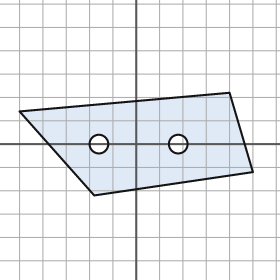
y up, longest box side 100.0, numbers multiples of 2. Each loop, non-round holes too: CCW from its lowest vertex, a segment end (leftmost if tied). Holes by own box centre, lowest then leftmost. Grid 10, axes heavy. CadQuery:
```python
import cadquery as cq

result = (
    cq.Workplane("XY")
    .moveTo(-18.0, -22.0)
    .lineTo(50.0, -12.0)
    .lineTo(40.0, 22.0)
    .lineTo(-50.0, 14.0)
    .close()
    .moveTo(-16.0, 0.0)
    .circle(4.0)
    .moveTo(18.0, 0.0)
    .circle(4.0)
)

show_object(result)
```